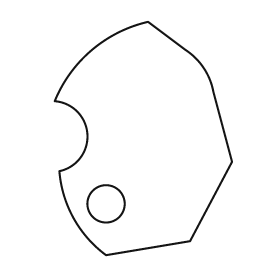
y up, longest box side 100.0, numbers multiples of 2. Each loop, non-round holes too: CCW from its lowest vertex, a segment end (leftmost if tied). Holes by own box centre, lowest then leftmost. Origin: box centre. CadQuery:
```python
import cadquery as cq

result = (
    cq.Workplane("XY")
    .moveTo(-16.0, -50.0)
    .lineTo(20.0, -44.0)
    .lineTo(38.0, -10.0)
    .lineTo(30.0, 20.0)
    .threePointArc((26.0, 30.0), (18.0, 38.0))
    .lineTo(2.0, 50.0)
    .threePointArc((-22.0, 38.0), (-38.0, 16.0))
    .threePointArc((-24.0, 2.0), (-36.0, -14.0))
    .threePointArc((-30.0, -34.0), (-16.0, -50.0))
    .close()
    .moveTo(-16.0, -28.0)
    .circle(8.0)
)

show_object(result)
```